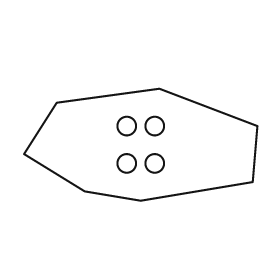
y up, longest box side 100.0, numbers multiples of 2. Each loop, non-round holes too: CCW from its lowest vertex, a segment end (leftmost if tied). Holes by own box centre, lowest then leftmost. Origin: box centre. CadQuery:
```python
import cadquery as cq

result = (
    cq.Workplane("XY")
    .moveTo(0.0, -24.0)
    .lineTo(48.0, -16.0)
    .lineTo(50.0, 8.0)
    .lineTo(8.0, 24.0)
    .lineTo(-36.0, 18.0)
    .lineTo(-50.0, -4.0)
    .lineTo(-24.0, -20.0)
    .close()
    .moveTo(-6.0, -8.0)
    .circle(4.0)
    .moveTo(6.0, -8.0)
    .circle(4.0)
    .moveTo(-6.0, 8.0)
    .circle(4.0)
    .moveTo(6.0, 8.0)
    .circle(4.0)
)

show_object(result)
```